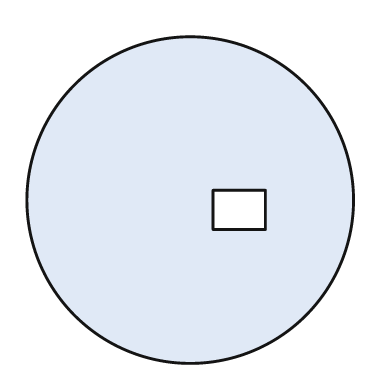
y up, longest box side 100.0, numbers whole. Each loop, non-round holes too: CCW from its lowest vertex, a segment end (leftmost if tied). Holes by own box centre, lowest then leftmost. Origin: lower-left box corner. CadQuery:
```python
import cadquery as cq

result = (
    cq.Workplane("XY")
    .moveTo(50.0, 50.0)
    .circle(50.0)
    .moveTo(57.0, 41.0)
    .lineTo(73.0, 41.0)
    .lineTo(73.0, 53.0)
    .lineTo(57.0, 53.0)
    .close()
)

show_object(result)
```